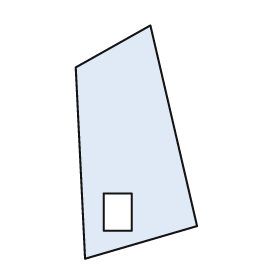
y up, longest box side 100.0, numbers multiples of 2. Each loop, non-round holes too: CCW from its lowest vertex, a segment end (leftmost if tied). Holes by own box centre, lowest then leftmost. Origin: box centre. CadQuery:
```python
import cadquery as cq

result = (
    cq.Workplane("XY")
    .moveTo(-22.0, -50.0)
    .lineTo(26.0, -36.0)
    .lineTo(6.0, 50.0)
    .lineTo(-26.0, 32.0)
    .close()
    .moveTo(-14.0, -38.0)
    .lineTo(-2.0, -38.0)
    .lineTo(-2.0, -22.0)
    .lineTo(-14.0, -22.0)
    .close()
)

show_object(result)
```